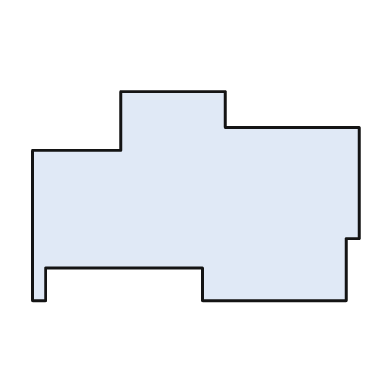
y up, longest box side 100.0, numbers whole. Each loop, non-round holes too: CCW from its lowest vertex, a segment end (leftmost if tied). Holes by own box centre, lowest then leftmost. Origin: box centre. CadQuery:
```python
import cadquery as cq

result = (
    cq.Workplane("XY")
    .moveTo(-50.0, -32.0)
    .lineTo(-46.0, -32.0)
    .lineTo(-46.0, -22.0)
    .lineTo(2.0, -22.0)
    .lineTo(2.0, -32.0)
    .lineTo(46.0, -32.0)
    .lineTo(46.0, -13.0)
    .lineTo(50.0, -13.0)
    .lineTo(50.0, 21.0)
    .lineTo(9.0, 21.0)
    .lineTo(9.0, 32.0)
    .lineTo(-23.0, 32.0)
    .lineTo(-23.0, 14.0)
    .lineTo(-50.0, 14.0)
    .close()
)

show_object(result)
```